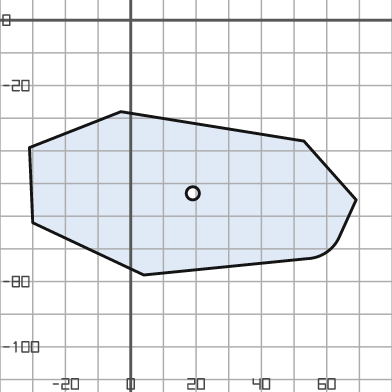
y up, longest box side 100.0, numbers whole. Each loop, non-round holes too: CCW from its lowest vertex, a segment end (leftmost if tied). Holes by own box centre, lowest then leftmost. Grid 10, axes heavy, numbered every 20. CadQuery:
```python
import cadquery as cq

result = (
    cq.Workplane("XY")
    .moveTo(4.0, -78.0)
    .lineTo(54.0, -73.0)
    .threePointArc((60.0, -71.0), (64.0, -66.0))
    .lineTo(69.0, -55.0)
    .lineTo(53.0, -37.0)
    .lineTo(-3.0, -28.0)
    .lineTo(-31.0, -39.0)
    .lineTo(-30.0, -62.0)
    .close()
    .moveTo(19.0, -53.0)
    .circle(2.0)
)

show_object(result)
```